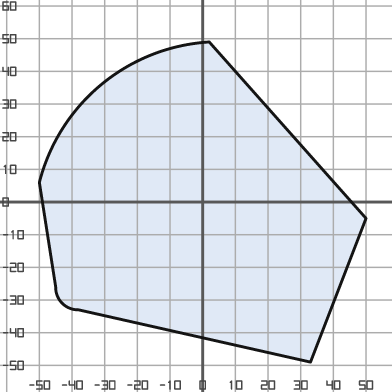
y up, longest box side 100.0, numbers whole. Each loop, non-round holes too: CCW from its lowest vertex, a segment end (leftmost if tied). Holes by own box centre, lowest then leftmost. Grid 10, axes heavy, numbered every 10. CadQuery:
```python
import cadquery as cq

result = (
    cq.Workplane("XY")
    .moveTo(33.0, -49.0)
    .lineTo(50.0, -5.0)
    .lineTo(2.0, 49.0)
    .threePointArc((-31.0, 36.0), (-50.0, 6.0))
    .lineTo(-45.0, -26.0)
    .threePointArc((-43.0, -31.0), (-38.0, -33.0))
    .close()
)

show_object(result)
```